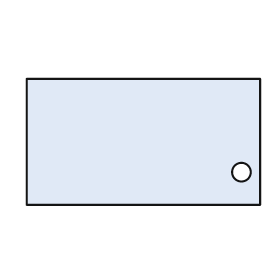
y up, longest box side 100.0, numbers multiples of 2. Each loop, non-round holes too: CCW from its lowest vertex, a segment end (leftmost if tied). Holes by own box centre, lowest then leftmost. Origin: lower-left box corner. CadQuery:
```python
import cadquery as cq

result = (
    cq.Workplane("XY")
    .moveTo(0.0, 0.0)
    .lineTo(100.0, 0.0)
    .lineTo(100.0, 54.0)
    .lineTo(0.0, 54.0)
    .close()
    .moveTo(92.0, 14.0)
    .circle(4.0)
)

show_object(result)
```